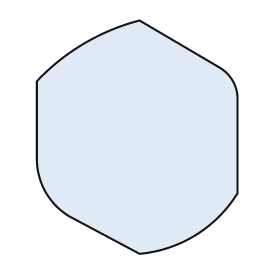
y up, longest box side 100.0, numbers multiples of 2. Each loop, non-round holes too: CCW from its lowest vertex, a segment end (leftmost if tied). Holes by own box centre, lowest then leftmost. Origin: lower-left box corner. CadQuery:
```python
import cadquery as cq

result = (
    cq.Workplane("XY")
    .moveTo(44.0, 0.0)
    .threePointArc((68.0, 8.0), (86.0, 26.0))
    .lineTo(86.0, 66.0)
    .threePointArc((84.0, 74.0), (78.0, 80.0))
    .lineTo(44.0, 100.0)
    .threePointArc((20.0, 90.0), (0.0, 74.0))
    .lineTo(0.0, 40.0)
    .threePointArc((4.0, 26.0), (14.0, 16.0))
    .close()
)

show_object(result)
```